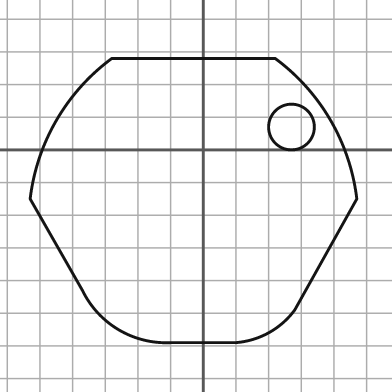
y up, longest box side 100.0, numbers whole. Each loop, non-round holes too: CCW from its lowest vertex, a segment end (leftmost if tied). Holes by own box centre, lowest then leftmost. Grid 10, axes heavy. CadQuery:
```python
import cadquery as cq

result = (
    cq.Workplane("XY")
    .moveTo(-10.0, -59.0)
    .lineTo(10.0, -59.0)
    .threePointArc((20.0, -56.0), (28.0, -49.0))
    .lineTo(47.0, -15.0)
    .threePointArc((39.0, 9.0), (22.0, 28.0))
    .lineTo(-28.0, 28.0)
    .threePointArc((-45.0, 9.0), (-53.0, -15.0))
    .lineTo(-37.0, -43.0)
    .threePointArc((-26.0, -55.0), (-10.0, -59.0))
    .close()
    .moveTo(27.0, 7.0)
    .circle(7.0)
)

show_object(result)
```